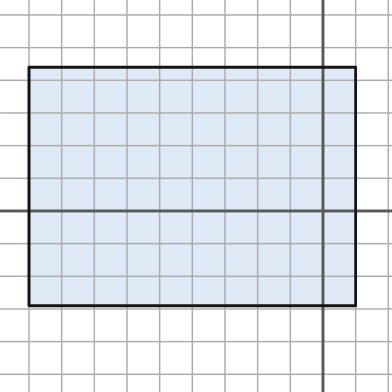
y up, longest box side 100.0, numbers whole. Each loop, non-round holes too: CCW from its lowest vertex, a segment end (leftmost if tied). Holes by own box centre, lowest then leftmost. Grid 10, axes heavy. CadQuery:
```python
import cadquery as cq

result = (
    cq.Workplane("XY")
    .moveTo(-90.0, -29.0)
    .lineTo(10.0, -29.0)
    .lineTo(10.0, 44.0)
    .lineTo(-90.0, 44.0)
    .close()
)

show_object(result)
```